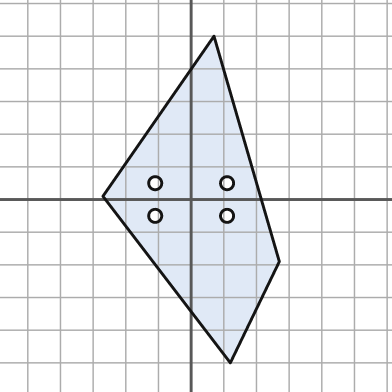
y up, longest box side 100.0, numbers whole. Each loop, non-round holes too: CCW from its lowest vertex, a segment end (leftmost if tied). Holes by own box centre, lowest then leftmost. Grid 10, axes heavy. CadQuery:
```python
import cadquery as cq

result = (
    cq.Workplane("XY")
    .moveTo(12.0, -50.0)
    .lineTo(27.0, -19.0)
    .lineTo(7.0, 50.0)
    .lineTo(-27.0, 1.0)
    .close()
    .moveTo(-11.0, -5.0)
    .circle(2.0)
    .moveTo(11.0, -5.0)
    .circle(2.0)
    .moveTo(-11.0, 5.0)
    .circle(2.0)
    .moveTo(11.0, 5.0)
    .circle(2.0)
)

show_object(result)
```